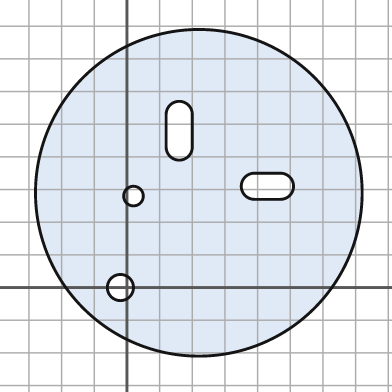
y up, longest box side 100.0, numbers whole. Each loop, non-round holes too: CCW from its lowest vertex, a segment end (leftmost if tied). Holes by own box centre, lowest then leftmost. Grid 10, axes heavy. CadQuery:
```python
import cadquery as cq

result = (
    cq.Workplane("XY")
    .moveTo(22.0, 29.0)
    .circle(50.0)
    .moveTo(-2.0, 0.0)
    .circle(4.0)
    .moveTo(2.0, 28.0)
    .circle(3.0)
    .moveTo(39.0, 27.0)
    .lineTo(47.0, 27.0)
    .threePointArc((51.0, 31.0), (47.0, 35.0))
    .lineTo(39.0, 35.0)
    .threePointArc((35.0, 31.0), (39.0, 27.0))
    .close()
    .moveTo(12.0, 43.0)
    .threePointArc((16.0, 39.0), (20.0, 43.0))
    .lineTo(20.0, 53.0)
    .threePointArc((16.0, 57.0), (12.0, 53.0))
    .close()
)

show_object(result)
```